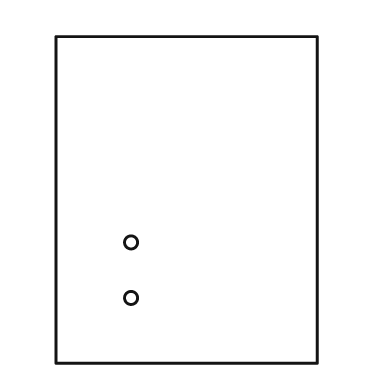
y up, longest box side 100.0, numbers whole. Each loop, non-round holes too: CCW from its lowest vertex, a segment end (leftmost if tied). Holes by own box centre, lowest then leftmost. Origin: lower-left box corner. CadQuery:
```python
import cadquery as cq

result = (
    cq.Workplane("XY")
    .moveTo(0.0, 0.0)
    .lineTo(80.0, 0.0)
    .lineTo(80.0, 100.0)
    .lineTo(0.0, 100.0)
    .close()
    .moveTo(23.0, 20.0)
    .circle(2.0)
    .moveTo(23.0, 37.0)
    .circle(2.0)
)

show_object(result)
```